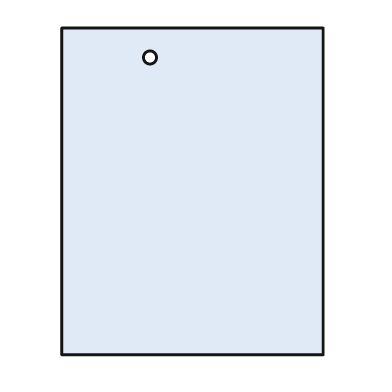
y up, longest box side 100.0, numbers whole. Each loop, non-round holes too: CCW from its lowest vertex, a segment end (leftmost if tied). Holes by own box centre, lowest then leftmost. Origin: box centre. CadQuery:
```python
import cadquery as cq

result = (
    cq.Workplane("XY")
    .moveTo(-40.0, -50.0)
    .lineTo(40.0, -50.0)
    .lineTo(40.0, 50.0)
    .lineTo(-40.0, 50.0)
    .close()
    .moveTo(-13.0, 41.0)
    .circle(2.0)
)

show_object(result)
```